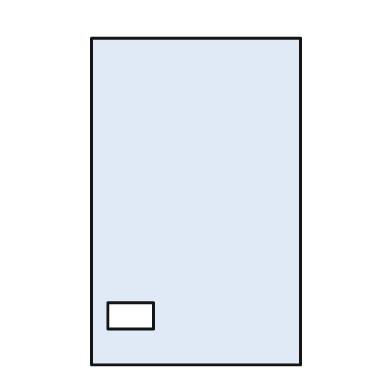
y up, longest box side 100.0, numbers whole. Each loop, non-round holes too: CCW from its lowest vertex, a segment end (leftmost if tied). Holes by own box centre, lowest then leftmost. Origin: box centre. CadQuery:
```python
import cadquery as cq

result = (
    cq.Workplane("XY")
    .moveTo(-32.0, -50.0)
    .lineTo(32.0, -50.0)
    .lineTo(32.0, 50.0)
    .lineTo(-32.0, 50.0)
    .close()
    .moveTo(-27.0, -39.0)
    .lineTo(-13.0, -39.0)
    .lineTo(-13.0, -31.0)
    .lineTo(-27.0, -31.0)
    .close()
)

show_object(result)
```